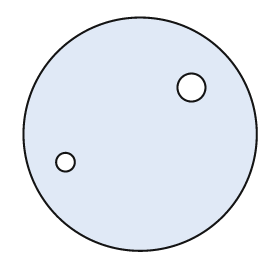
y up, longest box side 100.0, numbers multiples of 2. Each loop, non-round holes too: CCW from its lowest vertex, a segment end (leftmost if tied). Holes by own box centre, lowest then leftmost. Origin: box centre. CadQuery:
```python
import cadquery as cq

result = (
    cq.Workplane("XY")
    .moveTo(0.0, 0.0)
    .circle(50.0)
    .moveTo(-32.0, -12.0)
    .circle(4.0)
    .moveTo(22.0, 20.0)
    .circle(6.0)
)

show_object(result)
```